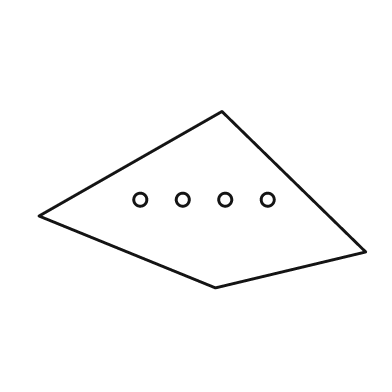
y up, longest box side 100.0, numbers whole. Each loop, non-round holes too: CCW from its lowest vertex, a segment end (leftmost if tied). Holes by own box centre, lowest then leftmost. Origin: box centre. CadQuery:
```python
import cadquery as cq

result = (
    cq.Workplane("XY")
    .moveTo(4.0, -27.0)
    .lineTo(50.0, -16.0)
    .lineTo(6.0, 27.0)
    .lineTo(-50.0, -5.0)
    .close()
    .moveTo(-19.0, 0.0)
    .circle(2.0)
    .moveTo(-6.0, 0.0)
    .circle(2.0)
    .moveTo(7.0, 0.0)
    .circle(2.0)
    .moveTo(20.0, 0.0)
    .circle(2.0)
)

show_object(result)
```